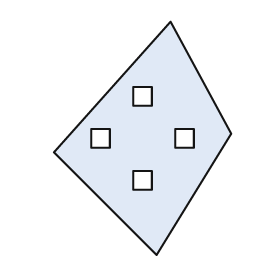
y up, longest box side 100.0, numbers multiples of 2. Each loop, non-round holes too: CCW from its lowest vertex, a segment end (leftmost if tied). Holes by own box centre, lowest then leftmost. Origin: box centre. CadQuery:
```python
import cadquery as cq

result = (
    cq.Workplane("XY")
    .moveTo(6.0, -50.0)
    .lineTo(38.0, 2.0)
    .lineTo(12.0, 50.0)
    .lineTo(-38.0, -6.0)
    .close()
    .moveTo(-4.0, -22.0)
    .lineTo(4.0, -22.0)
    .lineTo(4.0, -14.0)
    .lineTo(-4.0, -14.0)
    .close()
    .moveTo(-22.0, -4.0)
    .lineTo(-14.0, -4.0)
    .lineTo(-14.0, 4.0)
    .lineTo(-22.0, 4.0)
    .close()
    .moveTo(14.0, -4.0)
    .lineTo(22.0, -4.0)
    .lineTo(22.0, 4.0)
    .lineTo(14.0, 4.0)
    .close()
    .moveTo(-4.0, 14.0)
    .lineTo(4.0, 14.0)
    .lineTo(4.0, 22.0)
    .lineTo(-4.0, 22.0)
    .close()
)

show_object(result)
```